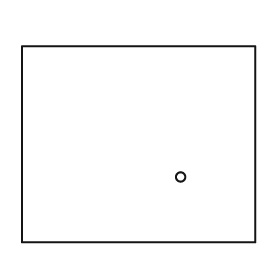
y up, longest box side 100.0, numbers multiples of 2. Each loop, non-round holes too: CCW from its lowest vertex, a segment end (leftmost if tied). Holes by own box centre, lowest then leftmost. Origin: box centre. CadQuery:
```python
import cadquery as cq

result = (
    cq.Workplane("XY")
    .moveTo(-50.0, -42.0)
    .lineTo(50.0, -42.0)
    .lineTo(50.0, 42.0)
    .lineTo(-50.0, 42.0)
    .close()
    .moveTo(18.0, -14.0)
    .circle(2.0)
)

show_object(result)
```